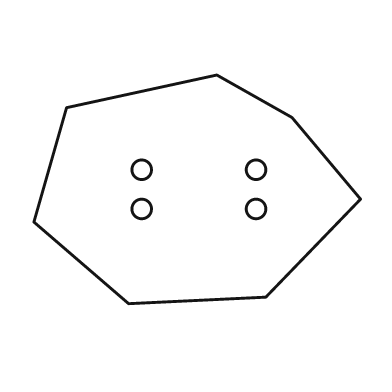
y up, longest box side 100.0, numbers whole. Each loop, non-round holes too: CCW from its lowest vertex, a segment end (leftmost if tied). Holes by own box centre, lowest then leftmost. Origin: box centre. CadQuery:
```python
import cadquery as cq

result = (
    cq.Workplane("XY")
    .moveTo(-21.0, -35.0)
    .lineTo(21.0, -33.0)
    .lineTo(50.0, -3.0)
    .lineTo(29.0, 22.0)
    .lineTo(6.0, 35.0)
    .lineTo(-40.0, 25.0)
    .lineTo(-50.0, -10.0)
    .close()
    .moveTo(-17.0, -6.0)
    .circle(3.0)
    .moveTo(18.0, -6.0)
    .circle(3.0)
    .moveTo(-17.0, 6.0)
    .circle(3.0)
    .moveTo(18.0, 6.0)
    .circle(3.0)
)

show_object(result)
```